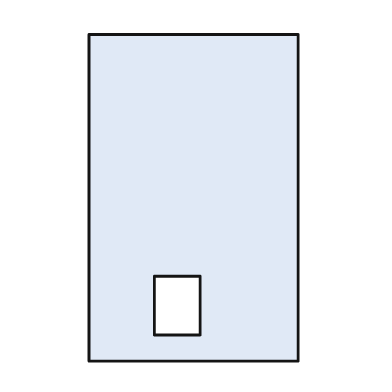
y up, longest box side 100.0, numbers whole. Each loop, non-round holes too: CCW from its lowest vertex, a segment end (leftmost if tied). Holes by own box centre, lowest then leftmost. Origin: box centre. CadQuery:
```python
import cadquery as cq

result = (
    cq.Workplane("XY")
    .moveTo(-32.0, -50.0)
    .lineTo(32.0, -50.0)
    .lineTo(32.0, 50.0)
    .lineTo(-32.0, 50.0)
    .close()
    .moveTo(-12.0, -42.0)
    .lineTo(2.0, -42.0)
    .lineTo(2.0, -24.0)
    .lineTo(-12.0, -24.0)
    .close()
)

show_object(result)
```